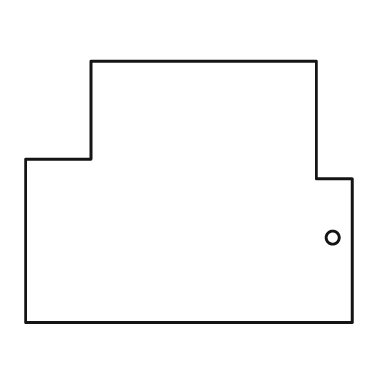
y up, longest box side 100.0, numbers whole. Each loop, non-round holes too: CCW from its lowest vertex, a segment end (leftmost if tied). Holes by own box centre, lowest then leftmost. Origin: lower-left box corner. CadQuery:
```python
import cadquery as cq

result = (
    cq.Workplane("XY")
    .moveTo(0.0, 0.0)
    .lineTo(100.0, 0.0)
    .lineTo(100.0, 44.0)
    .lineTo(89.0, 44.0)
    .lineTo(89.0, 80.0)
    .lineTo(20.0, 80.0)
    .lineTo(20.0, 50.0)
    .lineTo(0.0, 50.0)
    .close()
    .moveTo(94.0, 26.0)
    .circle(2.0)
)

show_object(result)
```